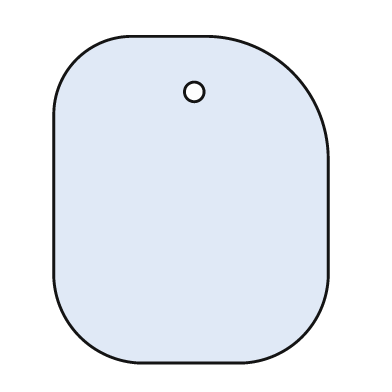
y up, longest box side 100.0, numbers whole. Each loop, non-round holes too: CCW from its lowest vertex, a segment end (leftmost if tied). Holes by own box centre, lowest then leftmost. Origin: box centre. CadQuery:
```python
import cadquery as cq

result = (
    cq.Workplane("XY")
    .moveTo(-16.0, -50.0)
    .lineTo(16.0, -50.0)
    .threePointArc((34.0, -42.0), (42.0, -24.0))
    .lineTo(42.0, 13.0)
    .threePointArc((31.0, 39.0), (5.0, 50.0))
    .lineTo(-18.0, 50.0)
    .threePointArc((-35.0, 43.0), (-42.0, 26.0))
    .lineTo(-42.0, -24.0)
    .threePointArc((-34.0, -42.0), (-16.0, -50.0))
    .close()
    .moveTo(1.0, 33.0)
    .circle(3.0)
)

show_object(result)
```